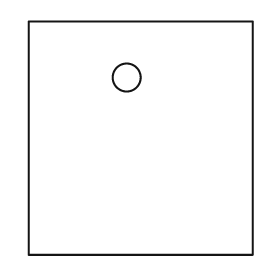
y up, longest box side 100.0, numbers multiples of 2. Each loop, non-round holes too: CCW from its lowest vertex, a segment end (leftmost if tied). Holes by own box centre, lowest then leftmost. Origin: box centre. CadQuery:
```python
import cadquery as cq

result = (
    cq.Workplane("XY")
    .moveTo(-48.0, -50.0)
    .lineTo(48.0, -50.0)
    .lineTo(48.0, 50.0)
    .lineTo(-48.0, 50.0)
    .close()
    .moveTo(-6.0, 26.0)
    .circle(6.0)
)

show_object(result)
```